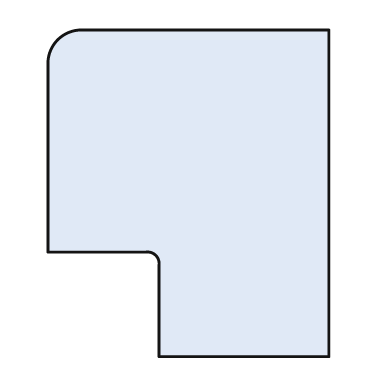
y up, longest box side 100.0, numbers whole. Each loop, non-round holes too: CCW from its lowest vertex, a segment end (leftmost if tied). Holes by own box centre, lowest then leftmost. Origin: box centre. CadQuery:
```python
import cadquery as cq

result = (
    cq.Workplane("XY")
    .moveTo(-9.0, -50.0)
    .lineTo(43.0, -50.0)
    .lineTo(43.0, 50.0)
    .lineTo(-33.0, 50.0)
    .threePointArc((-40.0, 47.0), (-43.0, 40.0))
    .lineTo(-43.0, -18.0)
    .lineTo(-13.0, -18.0)
    .threePointArc((-10.0, -19.0), (-9.0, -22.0))
    .close()
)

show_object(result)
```